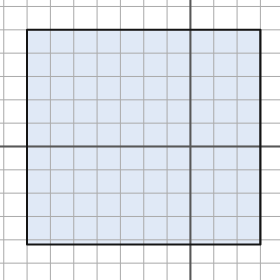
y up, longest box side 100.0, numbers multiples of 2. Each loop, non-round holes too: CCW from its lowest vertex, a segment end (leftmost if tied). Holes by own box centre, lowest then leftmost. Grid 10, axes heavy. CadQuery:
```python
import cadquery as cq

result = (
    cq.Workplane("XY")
    .moveTo(-70.0, -42.0)
    .lineTo(30.0, -42.0)
    .lineTo(30.0, 50.0)
    .lineTo(-70.0, 50.0)
    .close()
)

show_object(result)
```